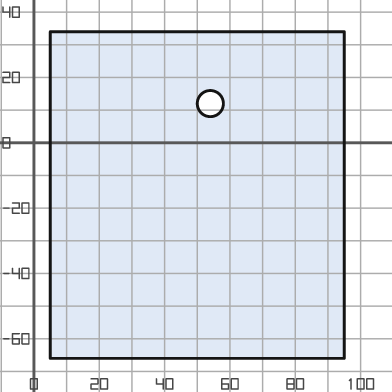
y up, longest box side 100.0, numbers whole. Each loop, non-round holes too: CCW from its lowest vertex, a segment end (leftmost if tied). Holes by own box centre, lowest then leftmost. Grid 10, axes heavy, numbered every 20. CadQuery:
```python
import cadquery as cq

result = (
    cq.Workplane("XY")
    .moveTo(5.0, -66.0)
    .lineTo(95.0, -66.0)
    .lineTo(95.0, 34.0)
    .lineTo(5.0, 34.0)
    .close()
    .moveTo(54.0, 12.0)
    .circle(4.0)
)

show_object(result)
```